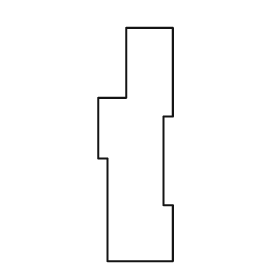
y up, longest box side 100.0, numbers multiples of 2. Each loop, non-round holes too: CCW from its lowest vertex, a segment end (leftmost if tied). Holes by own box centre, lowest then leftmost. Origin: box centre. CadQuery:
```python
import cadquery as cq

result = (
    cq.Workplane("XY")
    .moveTo(-12.0, -50.0)
    .lineTo(16.0, -50.0)
    .lineTo(16.0, -26.0)
    .lineTo(12.0, -26.0)
    .lineTo(12.0, 12.0)
    .lineTo(16.0, 12.0)
    .lineTo(16.0, 50.0)
    .lineTo(-4.0, 50.0)
    .lineTo(-4.0, 20.0)
    .lineTo(-16.0, 20.0)
    .lineTo(-16.0, -6.0)
    .lineTo(-12.0, -6.0)
    .close()
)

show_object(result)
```